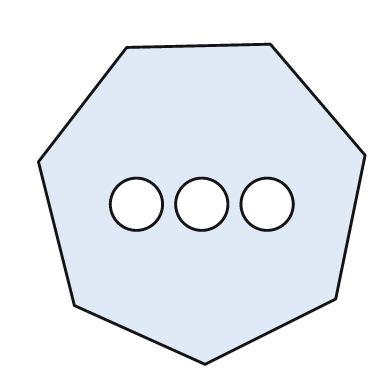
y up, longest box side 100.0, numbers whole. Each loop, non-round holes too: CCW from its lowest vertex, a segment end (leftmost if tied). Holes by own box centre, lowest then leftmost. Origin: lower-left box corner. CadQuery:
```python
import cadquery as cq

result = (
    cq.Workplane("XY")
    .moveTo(51.0, 0.0)
    .lineTo(91.0, 20.0)
    .lineTo(100.0, 64.0)
    .lineTo(71.0, 98.0)
    .lineTo(27.0, 97.0)
    .lineTo(0.0, 62.0)
    .lineTo(11.0, 18.0)
    .close()
    .moveTo(30.0, 49.0)
    .circle(8.0)
    .moveTo(50.0, 49.0)
    .circle(8.0)
    .moveTo(70.0, 49.0)
    .circle(8.0)
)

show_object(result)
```